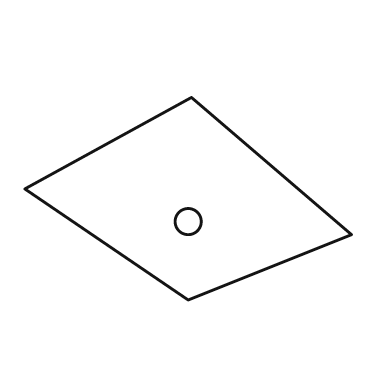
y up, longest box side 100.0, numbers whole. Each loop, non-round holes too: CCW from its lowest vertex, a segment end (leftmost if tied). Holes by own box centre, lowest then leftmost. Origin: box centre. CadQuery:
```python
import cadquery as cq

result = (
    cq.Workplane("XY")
    .moveTo(0.0, -31.0)
    .lineTo(50.0, -11.0)
    .lineTo(1.0, 31.0)
    .lineTo(-50.0, 3.0)
    .close()
    .moveTo(0.0, -7.0)
    .circle(4.0)
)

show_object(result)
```